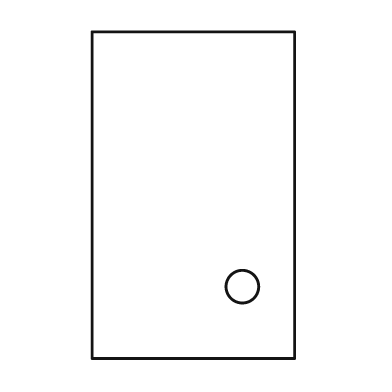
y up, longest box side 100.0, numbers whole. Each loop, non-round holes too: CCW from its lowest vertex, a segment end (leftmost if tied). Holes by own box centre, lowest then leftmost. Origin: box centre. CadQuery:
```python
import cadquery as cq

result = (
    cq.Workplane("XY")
    .moveTo(-31.0, -50.0)
    .lineTo(31.0, -50.0)
    .lineTo(31.0, 50.0)
    .lineTo(-31.0, 50.0)
    .close()
    .moveTo(15.0, -28.0)
    .circle(5.0)
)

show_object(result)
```